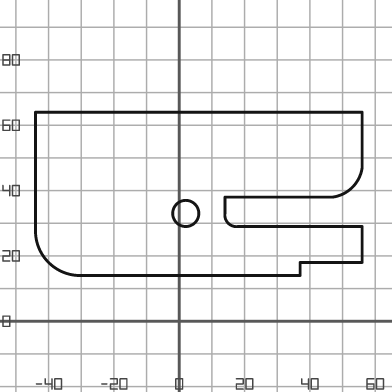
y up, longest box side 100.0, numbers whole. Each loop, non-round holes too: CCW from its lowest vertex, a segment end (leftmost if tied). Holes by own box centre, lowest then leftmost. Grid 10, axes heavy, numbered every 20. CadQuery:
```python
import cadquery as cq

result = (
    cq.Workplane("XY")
    .moveTo(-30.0, 14.0)
    .lineTo(37.0, 14.0)
    .lineTo(37.0, 18.0)
    .lineTo(56.0, 18.0)
    .lineTo(56.0, 29.0)
    .lineTo(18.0, 29.0)
    .threePointArc((15.0, 30.0), (14.0, 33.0))
    .lineTo(14.0, 38.0)
    .lineTo(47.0, 38.0)
    .threePointArc((53.0, 41.0), (56.0, 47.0))
    .lineTo(56.0, 64.0)
    .lineTo(-44.0, 64.0)
    .lineTo(-44.0, 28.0)
    .threePointArc((-40.0, 18.0), (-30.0, 14.0))
    .close()
    .moveTo(2.0, 33.0)
    .circle(4.0)
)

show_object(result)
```